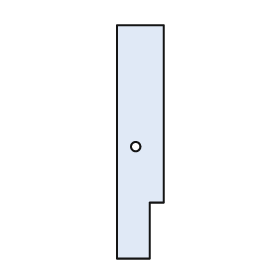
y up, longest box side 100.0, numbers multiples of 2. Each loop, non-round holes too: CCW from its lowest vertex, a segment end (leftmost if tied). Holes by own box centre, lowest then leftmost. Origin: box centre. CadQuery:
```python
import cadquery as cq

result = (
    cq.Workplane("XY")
    .moveTo(-10.0, -50.0)
    .lineTo(4.0, -50.0)
    .lineTo(4.0, -26.0)
    .lineTo(10.0, -26.0)
    .lineTo(10.0, 50.0)
    .lineTo(-10.0, 50.0)
    .close()
    .moveTo(-2.0, -2.0)
    .circle(2.0)
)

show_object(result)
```